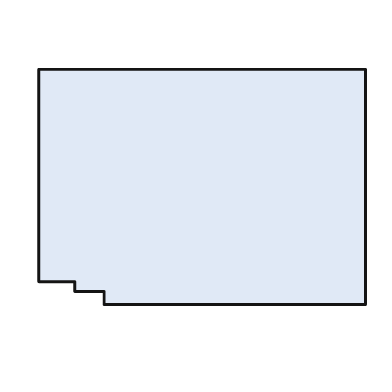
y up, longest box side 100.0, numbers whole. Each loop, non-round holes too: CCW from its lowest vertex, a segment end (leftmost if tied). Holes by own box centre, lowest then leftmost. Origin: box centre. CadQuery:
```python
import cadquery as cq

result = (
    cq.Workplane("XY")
    .moveTo(-30.0, -36.0)
    .lineTo(50.0, -36.0)
    .lineTo(50.0, 36.0)
    .lineTo(-50.0, 36.0)
    .lineTo(-50.0, -29.0)
    .lineTo(-39.0, -29.0)
    .lineTo(-39.0, -32.0)
    .lineTo(-30.0, -32.0)
    .close()
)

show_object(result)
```